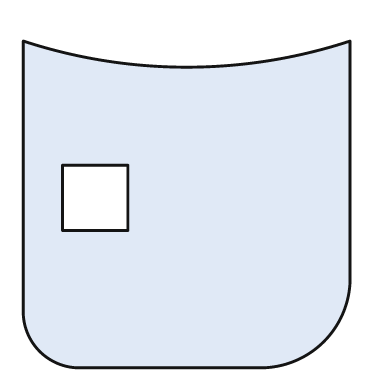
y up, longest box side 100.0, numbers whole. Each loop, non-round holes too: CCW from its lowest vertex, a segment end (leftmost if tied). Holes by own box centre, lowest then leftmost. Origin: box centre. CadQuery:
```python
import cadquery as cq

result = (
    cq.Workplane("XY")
    .moveTo(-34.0, -50.0)
    .lineTo(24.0, -50.0)
    .threePointArc((42.0, -42.0), (50.0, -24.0))
    .lineTo(50.0, 50.0)
    .threePointArc((0.0, 42.0), (-50.0, 50.0))
    .lineTo(-50.0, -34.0)
    .threePointArc((-45.0, -45.0), (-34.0, -50.0))
    .close()
    .moveTo(-38.0, -8.0)
    .lineTo(-18.0, -8.0)
    .lineTo(-18.0, 12.0)
    .lineTo(-38.0, 12.0)
    .close()
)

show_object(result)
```